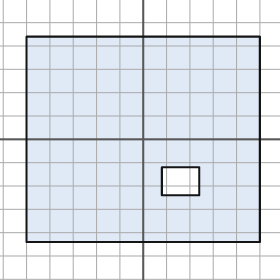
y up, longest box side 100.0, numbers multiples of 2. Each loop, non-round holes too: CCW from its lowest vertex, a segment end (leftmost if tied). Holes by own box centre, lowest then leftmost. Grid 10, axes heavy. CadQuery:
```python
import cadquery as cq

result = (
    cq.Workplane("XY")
    .moveTo(-50.0, -44.0)
    .lineTo(50.0, -44.0)
    .lineTo(50.0, 44.0)
    .lineTo(-50.0, 44.0)
    .close()
    .moveTo(8.0, -24.0)
    .lineTo(24.0, -24.0)
    .lineTo(24.0, -12.0)
    .lineTo(8.0, -12.0)
    .close()
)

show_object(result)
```